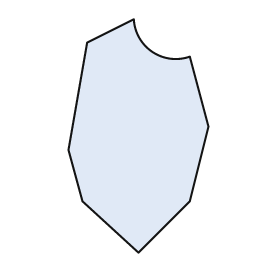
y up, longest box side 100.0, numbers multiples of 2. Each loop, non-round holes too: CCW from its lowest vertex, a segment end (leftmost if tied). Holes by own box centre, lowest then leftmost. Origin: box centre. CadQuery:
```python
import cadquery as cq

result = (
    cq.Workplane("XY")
    .moveTo(0.0, -50.0)
    .lineTo(22.0, -28.0)
    .lineTo(30.0, 4.0)
    .lineTo(22.0, 34.0)
    .threePointArc((6.0, 36.0), (-2.0, 50.0))
    .lineTo(-22.0, 40.0)
    .lineTo(-30.0, -6.0)
    .lineTo(-24.0, -28.0)
    .close()
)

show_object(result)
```